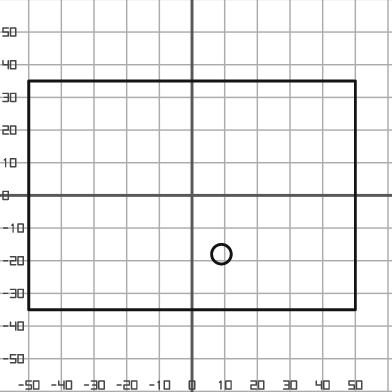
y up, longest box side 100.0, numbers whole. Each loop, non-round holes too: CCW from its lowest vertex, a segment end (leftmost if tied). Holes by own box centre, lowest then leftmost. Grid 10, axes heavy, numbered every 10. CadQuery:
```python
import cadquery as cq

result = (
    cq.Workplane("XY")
    .moveTo(-50.0, -35.0)
    .lineTo(50.0, -35.0)
    .lineTo(50.0, 35.0)
    .lineTo(-50.0, 35.0)
    .close()
    .moveTo(9.0, -18.0)
    .circle(3.0)
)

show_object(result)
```